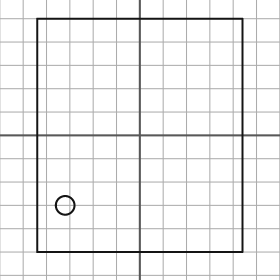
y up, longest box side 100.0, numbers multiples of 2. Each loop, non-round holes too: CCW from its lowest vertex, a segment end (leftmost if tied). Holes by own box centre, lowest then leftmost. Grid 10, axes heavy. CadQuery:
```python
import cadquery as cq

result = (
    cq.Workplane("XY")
    .moveTo(-44.0, -50.0)
    .lineTo(44.0, -50.0)
    .lineTo(44.0, 50.0)
    .lineTo(-44.0, 50.0)
    .close()
    .moveTo(-32.0, -30.0)
    .circle(4.0)
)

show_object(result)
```